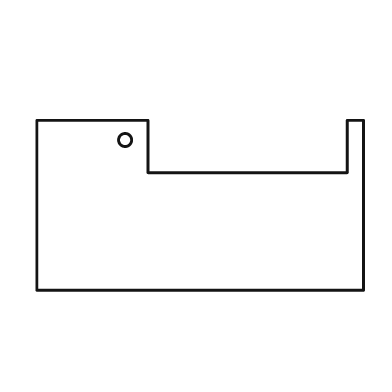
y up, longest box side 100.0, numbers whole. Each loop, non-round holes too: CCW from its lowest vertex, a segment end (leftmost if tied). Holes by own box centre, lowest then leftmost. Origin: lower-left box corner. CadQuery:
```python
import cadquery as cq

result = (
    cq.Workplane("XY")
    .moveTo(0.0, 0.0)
    .lineTo(100.0, 0.0)
    .lineTo(100.0, 52.0)
    .lineTo(95.0, 52.0)
    .lineTo(95.0, 36.0)
    .lineTo(34.0, 36.0)
    .lineTo(34.0, 52.0)
    .lineTo(0.0, 52.0)
    .close()
    .moveTo(27.0, 46.0)
    .circle(2.0)
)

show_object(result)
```